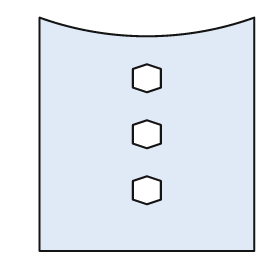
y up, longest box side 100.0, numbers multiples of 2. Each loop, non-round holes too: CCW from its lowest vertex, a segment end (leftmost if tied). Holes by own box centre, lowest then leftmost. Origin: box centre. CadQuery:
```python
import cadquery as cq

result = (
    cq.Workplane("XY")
    .moveTo(-46.0, -50.0)
    .lineTo(46.0, -50.0)
    .lineTo(46.0, 50.0)
    .threePointArc((0.0, 42.0), (-46.0, 50.0))
    .close()
    .moveTo(0.0, -30.0)
    .lineTo(6.0, -28.0)
    .lineTo(6.0, -20.0)
    .lineTo(0.0, -18.0)
    .lineTo(-6.0, -20.0)
    .lineTo(-6.0, -28.0)
    .close()
    .moveTo(0.0, -6.0)
    .lineTo(6.0, -4.0)
    .lineTo(6.0, 4.0)
    .lineTo(0.0, 6.0)
    .lineTo(-6.0, 4.0)
    .lineTo(-6.0, -4.0)
    .close()
    .moveTo(0.0, 18.0)
    .lineTo(6.0, 20.0)
    .lineTo(6.0, 28.0)
    .lineTo(0.0, 30.0)
    .lineTo(-6.0, 28.0)
    .lineTo(-6.0, 20.0)
    .close()
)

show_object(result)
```